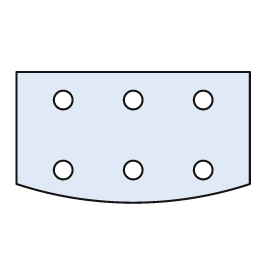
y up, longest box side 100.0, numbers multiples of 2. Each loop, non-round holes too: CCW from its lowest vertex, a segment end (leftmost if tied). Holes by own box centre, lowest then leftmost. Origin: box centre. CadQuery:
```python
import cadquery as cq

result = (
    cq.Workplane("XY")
    .moveTo(-50.0, -20.0)
    .threePointArc((0.0, -28.0), (50.0, -20.0))
    .lineTo(50.0, 28.0)
    .lineTo(-50.0, 28.0)
    .close()
    .moveTo(-30.0, -14.0)
    .circle(4.0)
    .moveTo(0.0, -14.0)
    .circle(4.0)
    .moveTo(30.0, -14.0)
    .circle(4.0)
    .moveTo(-30.0, 16.0)
    .circle(4.0)
    .moveTo(0.0, 16.0)
    .circle(4.0)
    .moveTo(30.0, 16.0)
    .circle(4.0)
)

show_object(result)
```